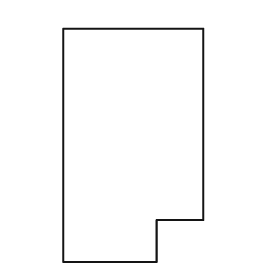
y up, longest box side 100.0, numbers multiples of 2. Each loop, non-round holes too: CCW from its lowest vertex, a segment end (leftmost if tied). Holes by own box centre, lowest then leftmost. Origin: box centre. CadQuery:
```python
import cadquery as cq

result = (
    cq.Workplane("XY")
    .moveTo(-30.0, -50.0)
    .lineTo(10.0, -50.0)
    .lineTo(10.0, -32.0)
    .lineTo(30.0, -32.0)
    .lineTo(30.0, 50.0)
    .lineTo(-30.0, 50.0)
    .close()
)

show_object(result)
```